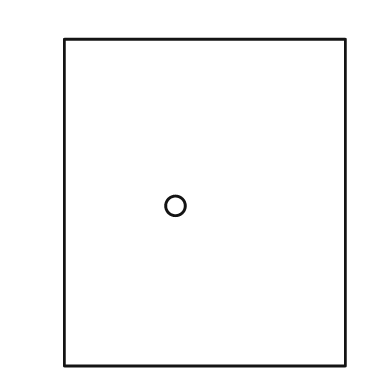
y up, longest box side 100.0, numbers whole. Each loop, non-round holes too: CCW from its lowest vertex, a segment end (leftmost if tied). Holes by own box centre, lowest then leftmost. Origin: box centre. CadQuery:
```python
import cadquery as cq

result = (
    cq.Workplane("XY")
    .moveTo(-43.0, -50.0)
    .lineTo(43.0, -50.0)
    .lineTo(43.0, 50.0)
    .lineTo(-43.0, 50.0)
    .close()
    .moveTo(-9.0, -1.0)
    .circle(3.0)
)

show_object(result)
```